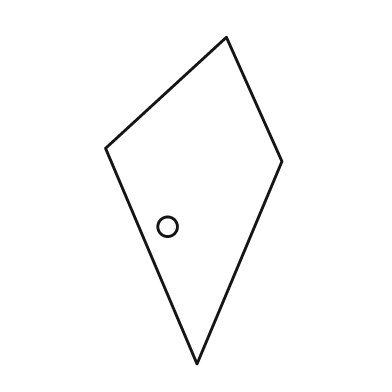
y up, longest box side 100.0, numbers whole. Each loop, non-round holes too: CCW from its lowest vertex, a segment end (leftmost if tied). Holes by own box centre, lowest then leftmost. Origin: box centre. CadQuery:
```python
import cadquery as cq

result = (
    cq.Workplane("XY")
    .moveTo(1.0, -50.0)
    .lineTo(27.0, 12.0)
    .lineTo(10.0, 50.0)
    .lineTo(-27.0, 16.0)
    .close()
    .moveTo(-8.0, -8.0)
    .circle(3.0)
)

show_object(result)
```